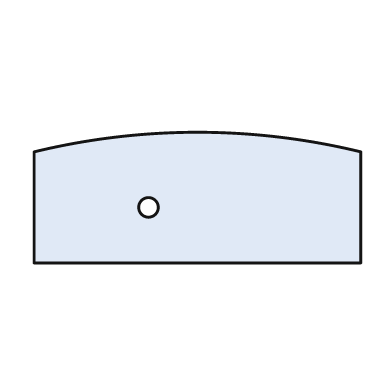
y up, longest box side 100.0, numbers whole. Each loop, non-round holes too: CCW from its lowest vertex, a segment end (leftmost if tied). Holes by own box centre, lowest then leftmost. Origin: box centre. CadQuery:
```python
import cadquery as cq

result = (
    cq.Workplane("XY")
    .moveTo(-50.0, -20.0)
    .lineTo(50.0, -20.0)
    .lineTo(50.0, 14.0)
    .threePointArc((0.0, 20.0), (-50.0, 14.0))
    .close()
    .moveTo(-15.0, -3.0)
    .circle(3.0)
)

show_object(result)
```